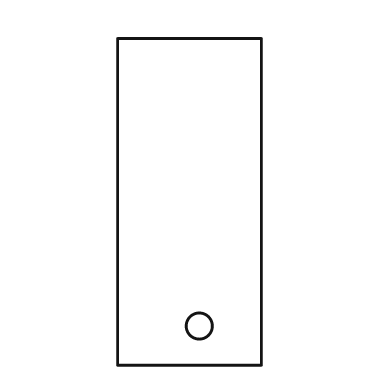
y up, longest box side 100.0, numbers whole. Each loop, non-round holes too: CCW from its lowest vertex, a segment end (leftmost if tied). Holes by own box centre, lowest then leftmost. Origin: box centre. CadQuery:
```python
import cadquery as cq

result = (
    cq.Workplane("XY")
    .moveTo(-22.0, -50.0)
    .lineTo(22.0, -50.0)
    .lineTo(22.0, 50.0)
    .lineTo(-22.0, 50.0)
    .close()
    .moveTo(3.0, -38.0)
    .circle(4.0)
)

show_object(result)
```